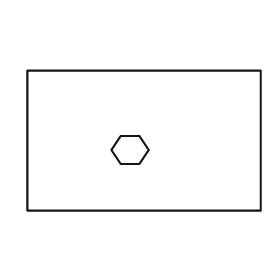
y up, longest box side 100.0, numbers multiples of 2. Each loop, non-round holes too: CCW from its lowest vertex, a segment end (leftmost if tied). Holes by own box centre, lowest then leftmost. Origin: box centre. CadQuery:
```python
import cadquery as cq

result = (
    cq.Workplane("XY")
    .moveTo(-50.0, -30.0)
    .lineTo(50.0, -30.0)
    .lineTo(50.0, 30.0)
    .lineTo(-50.0, 30.0)
    .close()
    .moveTo(-10.0, -10.0)
    .lineTo(-2.0, -10.0)
    .lineTo(2.0, -4.0)
    .lineTo(-2.0, 2.0)
    .lineTo(-10.0, 2.0)
    .lineTo(-14.0, -4.0)
    .close()
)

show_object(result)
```